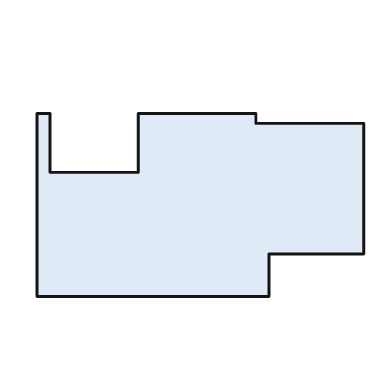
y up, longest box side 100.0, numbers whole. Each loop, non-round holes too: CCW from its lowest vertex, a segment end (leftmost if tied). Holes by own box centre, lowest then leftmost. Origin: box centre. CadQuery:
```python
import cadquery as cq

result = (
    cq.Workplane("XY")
    .moveTo(-50.0, -28.0)
    .lineTo(21.0, -28.0)
    .lineTo(21.0, -15.0)
    .lineTo(50.0, -15.0)
    .lineTo(50.0, 25.0)
    .lineTo(17.0, 25.0)
    .lineTo(17.0, 28.0)
    .lineTo(-19.0, 28.0)
    .lineTo(-19.0, 10.0)
    .lineTo(-46.0, 10.0)
    .lineTo(-46.0, 28.0)
    .lineTo(-50.0, 28.0)
    .close()
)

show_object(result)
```